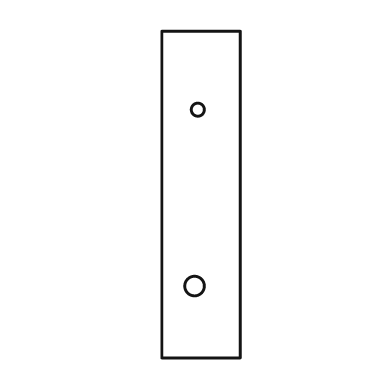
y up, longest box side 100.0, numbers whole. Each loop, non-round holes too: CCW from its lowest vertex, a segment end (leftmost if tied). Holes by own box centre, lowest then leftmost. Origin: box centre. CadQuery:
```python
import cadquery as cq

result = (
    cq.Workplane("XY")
    .moveTo(-12.0, -50.0)
    .lineTo(12.0, -50.0)
    .lineTo(12.0, 50.0)
    .lineTo(-12.0, 50.0)
    .close()
    .moveTo(-2.0, -28.0)
    .circle(3.0)
    .moveTo(-1.0, 26.0)
    .circle(2.0)
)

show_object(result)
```